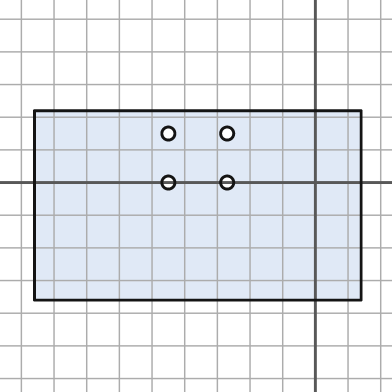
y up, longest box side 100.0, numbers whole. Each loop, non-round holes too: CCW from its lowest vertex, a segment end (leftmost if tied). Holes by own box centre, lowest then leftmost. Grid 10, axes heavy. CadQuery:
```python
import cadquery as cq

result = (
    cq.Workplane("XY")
    .moveTo(-86.0, -36.0)
    .lineTo(14.0, -36.0)
    .lineTo(14.0, 22.0)
    .lineTo(-86.0, 22.0)
    .close()
    .moveTo(-45.0, 0.0)
    .circle(2.0)
    .moveTo(-27.0, 0.0)
    .circle(2.0)
    .moveTo(-45.0, 15.0)
    .circle(2.0)
    .moveTo(-27.0, 15.0)
    .circle(2.0)
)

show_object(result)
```